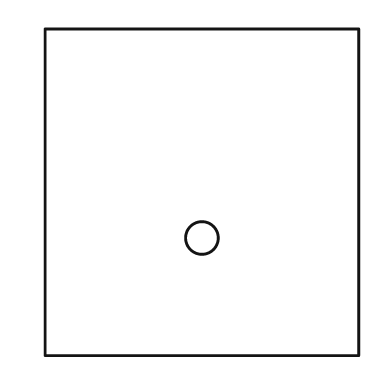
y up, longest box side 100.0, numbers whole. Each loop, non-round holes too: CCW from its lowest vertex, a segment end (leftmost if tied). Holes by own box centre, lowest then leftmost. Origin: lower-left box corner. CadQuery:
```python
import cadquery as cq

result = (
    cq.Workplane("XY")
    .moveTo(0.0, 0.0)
    .lineTo(96.0, 0.0)
    .lineTo(96.0, 100.0)
    .lineTo(0.0, 100.0)
    .close()
    .moveTo(48.0, 36.0)
    .circle(5.0)
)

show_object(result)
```